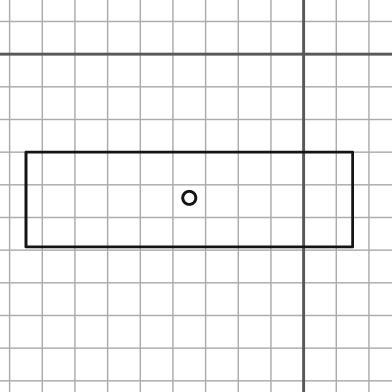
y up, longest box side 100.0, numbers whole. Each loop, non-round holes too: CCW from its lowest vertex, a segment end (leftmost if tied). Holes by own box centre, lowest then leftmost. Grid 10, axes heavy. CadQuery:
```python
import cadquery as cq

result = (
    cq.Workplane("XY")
    .moveTo(-85.0, -59.0)
    .lineTo(15.0, -59.0)
    .lineTo(15.0, -30.0)
    .lineTo(-85.0, -30.0)
    .close()
    .moveTo(-35.0, -44.0)
    .circle(2.0)
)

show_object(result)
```